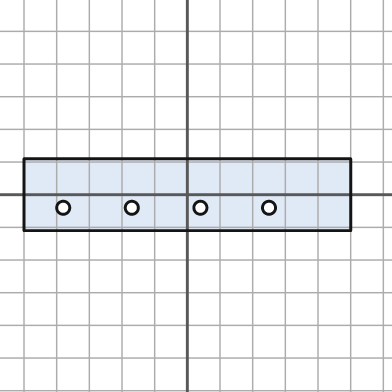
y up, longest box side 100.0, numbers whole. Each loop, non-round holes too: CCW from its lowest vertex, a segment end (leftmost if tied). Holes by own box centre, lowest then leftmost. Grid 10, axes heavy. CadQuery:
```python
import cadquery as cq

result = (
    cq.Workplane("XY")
    .moveTo(-50.0, -11.0)
    .lineTo(50.0, -11.0)
    .lineTo(50.0, 11.0)
    .lineTo(-50.0, 11.0)
    .close()
    .moveTo(-38.0, -4.0)
    .circle(2.0)
    .moveTo(-17.0, -4.0)
    .circle(2.0)
    .moveTo(4.0, -4.0)
    .circle(2.0)
    .moveTo(25.0, -4.0)
    .circle(2.0)
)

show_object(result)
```